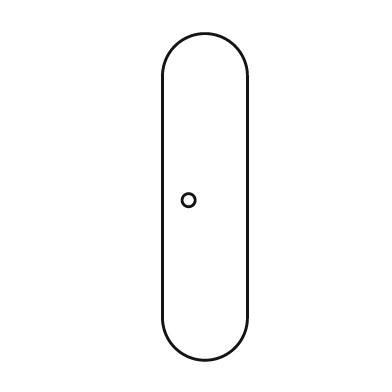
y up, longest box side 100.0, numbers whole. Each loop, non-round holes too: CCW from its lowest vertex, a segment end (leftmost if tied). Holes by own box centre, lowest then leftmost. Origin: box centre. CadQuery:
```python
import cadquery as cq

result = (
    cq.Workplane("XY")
    .moveTo(-13.0, -37.0)
    .threePointArc((0.0, -50.0), (13.0, -37.0))
    .lineTo(13.0, 37.0)
    .threePointArc((0.0, 50.0), (-13.0, 37.0))
    .close()
    .moveTo(-5.0, -1.0)
    .circle(2.0)
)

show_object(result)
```